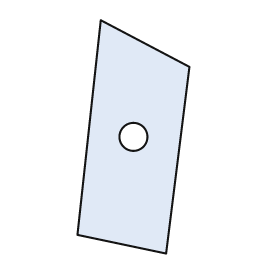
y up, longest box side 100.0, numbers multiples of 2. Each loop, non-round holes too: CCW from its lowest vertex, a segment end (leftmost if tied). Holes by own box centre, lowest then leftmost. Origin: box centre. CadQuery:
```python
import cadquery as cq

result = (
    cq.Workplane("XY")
    .moveTo(14.0, -50.0)
    .lineTo(24.0, 30.0)
    .lineTo(-14.0, 50.0)
    .lineTo(-24.0, -42.0)
    .close()
    .moveTo(0.0, 0.0)
    .circle(6.0)
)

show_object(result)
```